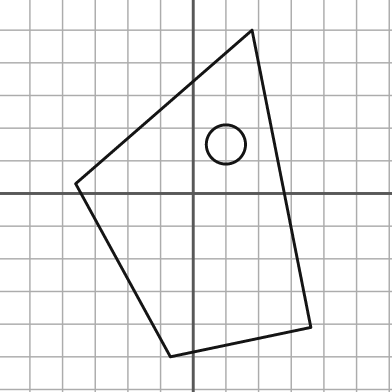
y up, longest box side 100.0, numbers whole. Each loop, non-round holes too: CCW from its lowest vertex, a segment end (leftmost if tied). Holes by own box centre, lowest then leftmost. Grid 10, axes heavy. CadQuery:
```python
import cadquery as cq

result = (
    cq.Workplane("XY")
    .moveTo(-7.0, -50.0)
    .lineTo(36.0, -41.0)
    .lineTo(18.0, 50.0)
    .lineTo(-36.0, 3.0)
    .close()
    .moveTo(10.0, 15.0)
    .circle(6.0)
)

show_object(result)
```